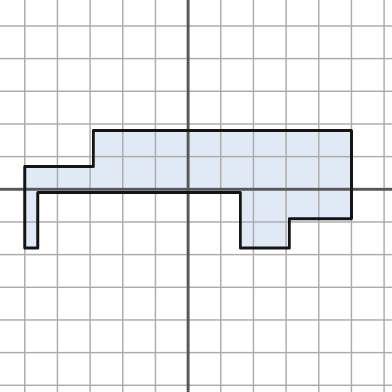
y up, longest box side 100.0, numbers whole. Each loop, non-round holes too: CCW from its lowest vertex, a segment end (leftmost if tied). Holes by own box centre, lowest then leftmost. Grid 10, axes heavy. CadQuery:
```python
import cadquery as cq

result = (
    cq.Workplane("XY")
    .moveTo(-50.0, -18.0)
    .lineTo(-46.0, -18.0)
    .lineTo(-46.0, -1.0)
    .lineTo(16.0, -1.0)
    .lineTo(16.0, -18.0)
    .lineTo(31.0, -18.0)
    .lineTo(31.0, -9.0)
    .lineTo(50.0, -9.0)
    .lineTo(50.0, 18.0)
    .lineTo(-29.0, 18.0)
    .lineTo(-29.0, 7.0)
    .lineTo(-50.0, 7.0)
    .close()
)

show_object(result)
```